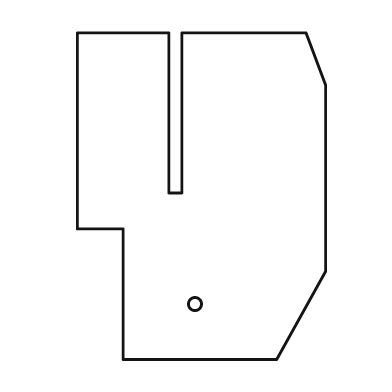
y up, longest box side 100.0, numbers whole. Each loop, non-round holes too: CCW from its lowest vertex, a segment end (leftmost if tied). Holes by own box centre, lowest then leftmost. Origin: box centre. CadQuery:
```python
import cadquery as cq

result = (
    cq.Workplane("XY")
    .moveTo(-24.0, -50.0)
    .lineTo(23.0, -50.0)
    .lineTo(38.0, -23.0)
    .lineTo(38.0, 34.0)
    .lineTo(32.0, 50.0)
    .lineTo(-6.0, 50.0)
    .lineTo(-6.0, 1.0)
    .lineTo(-10.0, 1.0)
    .lineTo(-10.0, 50.0)
    .lineTo(-38.0, 50.0)
    .lineTo(-38.0, -10.0)
    .lineTo(-24.0, -10.0)
    .close()
    .moveTo(-2.0, -33.0)
    .circle(2.0)
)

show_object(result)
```